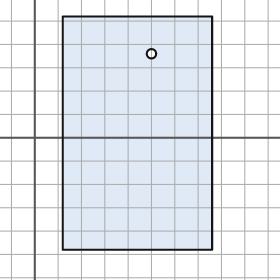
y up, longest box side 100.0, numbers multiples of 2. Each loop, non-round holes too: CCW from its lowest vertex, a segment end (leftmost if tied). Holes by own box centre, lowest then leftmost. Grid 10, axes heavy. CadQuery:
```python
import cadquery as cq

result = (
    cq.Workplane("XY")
    .moveTo(12.0, -48.0)
    .lineTo(76.0, -48.0)
    .lineTo(76.0, 52.0)
    .lineTo(12.0, 52.0)
    .close()
    .moveTo(50.0, 36.0)
    .circle(2.0)
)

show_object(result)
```